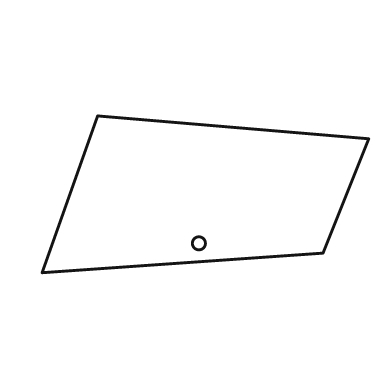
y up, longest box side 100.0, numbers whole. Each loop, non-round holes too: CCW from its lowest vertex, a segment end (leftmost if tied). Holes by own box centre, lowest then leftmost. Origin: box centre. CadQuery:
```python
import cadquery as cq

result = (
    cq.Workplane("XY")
    .moveTo(-50.0, -24.0)
    .lineTo(36.0, -18.0)
    .lineTo(50.0, 17.0)
    .lineTo(-33.0, 24.0)
    .close()
    .moveTo(-2.0, -15.0)
    .circle(2.0)
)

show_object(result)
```